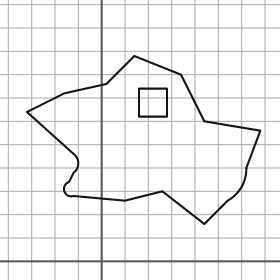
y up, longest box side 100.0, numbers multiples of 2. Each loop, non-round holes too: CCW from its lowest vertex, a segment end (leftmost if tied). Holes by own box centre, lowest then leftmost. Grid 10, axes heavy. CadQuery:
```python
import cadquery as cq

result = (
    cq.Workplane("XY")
    .moveTo(44.0, 16.0)
    .lineTo(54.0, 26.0)
    .threePointArc((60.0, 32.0), (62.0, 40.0))
    .lineTo(68.0, 56.0)
    .lineTo(44.0, 60.0)
    .lineTo(34.0, 80.0)
    .lineTo(14.0, 88.0)
    .lineTo(2.0, 76.0)
    .lineTo(-16.0, 72.0)
    .lineTo(-32.0, 64.0)
    .lineTo(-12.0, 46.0)
    .threePointArc((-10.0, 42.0), (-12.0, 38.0))
    .lineTo(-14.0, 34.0)
    .threePointArc((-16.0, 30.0), (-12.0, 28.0))
    .lineTo(10.0, 26.0)
    .lineTo(26.0, 30.0)
    .close()
    .moveTo(16.0, 62.0)
    .lineTo(28.0, 62.0)
    .lineTo(28.0, 74.0)
    .lineTo(16.0, 74.0)
    .close()
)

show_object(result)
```